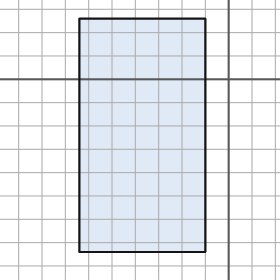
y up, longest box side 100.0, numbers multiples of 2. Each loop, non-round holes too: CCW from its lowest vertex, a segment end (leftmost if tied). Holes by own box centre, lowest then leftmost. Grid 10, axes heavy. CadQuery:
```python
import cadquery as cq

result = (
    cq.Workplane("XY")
    .moveTo(-64.0, -74.0)
    .lineTo(-10.0, -74.0)
    .lineTo(-10.0, 26.0)
    .lineTo(-64.0, 26.0)
    .close()
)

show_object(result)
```